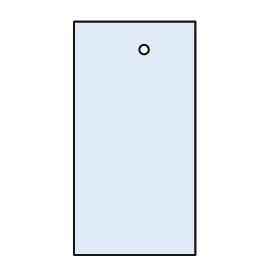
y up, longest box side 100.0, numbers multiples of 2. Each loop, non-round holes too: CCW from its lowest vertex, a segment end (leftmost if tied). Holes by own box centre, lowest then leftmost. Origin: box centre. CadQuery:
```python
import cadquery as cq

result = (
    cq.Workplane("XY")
    .moveTo(-26.0, -50.0)
    .lineTo(26.0, -50.0)
    .lineTo(26.0, 50.0)
    .lineTo(-26.0, 50.0)
    .close()
    .moveTo(4.0, 38.0)
    .circle(2.0)
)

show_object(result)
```